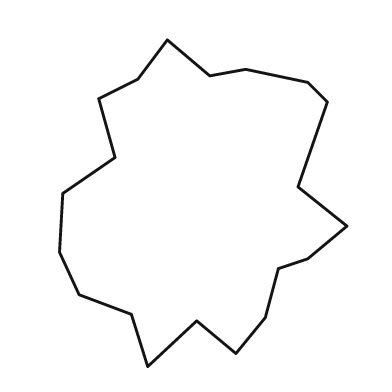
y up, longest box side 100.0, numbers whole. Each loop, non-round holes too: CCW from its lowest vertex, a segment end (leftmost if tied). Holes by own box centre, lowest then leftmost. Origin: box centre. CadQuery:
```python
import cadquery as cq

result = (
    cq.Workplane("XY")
    .moveTo(-17.0, -50.0)
    .lineTo(-2.0, -36.0)
    .lineTo(10.0, -46.0)
    .lineTo(19.0, -35.0)
    .lineTo(23.0, -20.0)
    .lineTo(32.0, -17.0)
    .lineTo(44.0, -7.0)
    .lineTo(29.0, 5.0)
    .lineTo(38.0, 31.0)
    .lineTo(32.0, 37.0)
    .lineTo(13.0, 41.0)
    .lineTo(2.0, 39.0)
    .lineTo(-11.0, 50.0)
    .lineTo(-20.0, 38.0)
    .lineTo(-32.0, 32.0)
    .lineTo(-27.0, 14.0)
    .lineTo(-43.0, 3.0)
    .lineTo(-44.0, -15.0)
    .lineTo(-38.0, -28.0)
    .lineTo(-22.0, -34.0)
    .close()
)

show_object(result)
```